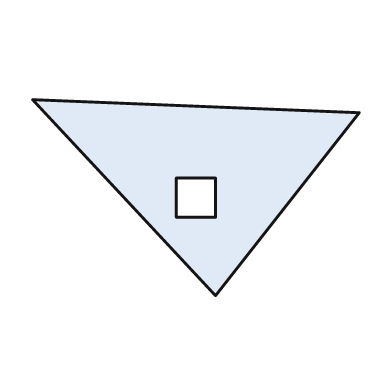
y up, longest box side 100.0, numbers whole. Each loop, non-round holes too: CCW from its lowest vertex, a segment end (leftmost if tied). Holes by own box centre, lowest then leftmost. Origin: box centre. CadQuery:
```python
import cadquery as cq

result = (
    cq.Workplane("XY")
    .moveTo(6.0, -30.0)
    .lineTo(50.0, 26.0)
    .lineTo(-50.0, 30.0)
    .close()
    .moveTo(-6.0, -6.0)
    .lineTo(6.0, -6.0)
    .lineTo(6.0, 6.0)
    .lineTo(-6.0, 6.0)
    .close()
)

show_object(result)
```